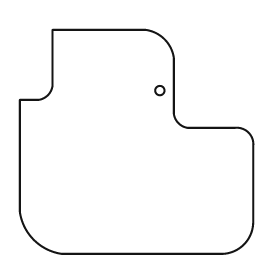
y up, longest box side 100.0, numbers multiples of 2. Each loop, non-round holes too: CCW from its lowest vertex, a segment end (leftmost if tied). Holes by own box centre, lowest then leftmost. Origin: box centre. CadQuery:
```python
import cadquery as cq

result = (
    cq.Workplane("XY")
    .moveTo(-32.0, -48.0)
    .lineTo(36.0, -48.0)
    .threePointArc((46.0, -44.0), (50.0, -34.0))
    .lineTo(50.0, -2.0)
    .threePointArc((48.0, 4.0), (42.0, 6.0))
    .lineTo(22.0, 6.0)
    .threePointArc((18.0, 8.0), (16.0, 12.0))
    .lineTo(16.0, 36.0)
    .threePointArc((12.0, 44.0), (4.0, 48.0))
    .lineTo(-36.0, 48.0)
    .lineTo(-36.0, 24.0)
    .threePointArc((-38.0, 20.0), (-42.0, 18.0))
    .lineTo(-50.0, 18.0)
    .lineTo(-50.0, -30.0)
    .threePointArc((-44.0, -42.0), (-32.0, -48.0))
    .close()
    .moveTo(10.0, 22.0)
    .circle(2.0)
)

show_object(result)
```